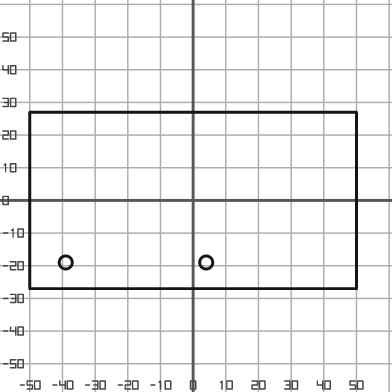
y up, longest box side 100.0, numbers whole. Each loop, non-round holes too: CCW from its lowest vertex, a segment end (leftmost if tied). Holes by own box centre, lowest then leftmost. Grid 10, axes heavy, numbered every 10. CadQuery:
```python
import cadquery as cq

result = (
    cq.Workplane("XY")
    .moveTo(-50.0, -27.0)
    .lineTo(50.0, -27.0)
    .lineTo(50.0, 27.0)
    .lineTo(-50.0, 27.0)
    .close()
    .moveTo(-39.0, -19.0)
    .circle(2.0)
    .moveTo(4.0, -19.0)
    .circle(2.0)
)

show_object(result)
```